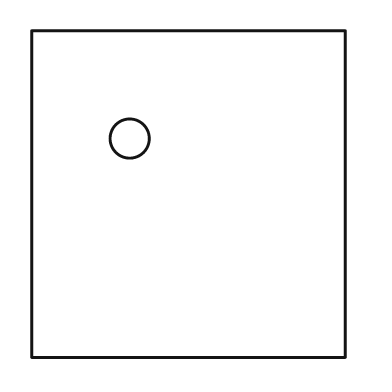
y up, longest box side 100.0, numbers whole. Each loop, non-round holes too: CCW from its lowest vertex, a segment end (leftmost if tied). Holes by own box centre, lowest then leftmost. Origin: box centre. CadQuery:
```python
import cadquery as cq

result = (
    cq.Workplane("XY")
    .moveTo(-48.0, -50.0)
    .lineTo(48.0, -50.0)
    .lineTo(48.0, 50.0)
    .lineTo(-48.0, 50.0)
    .close()
    .moveTo(-18.0, 17.0)
    .circle(6.0)
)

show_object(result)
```